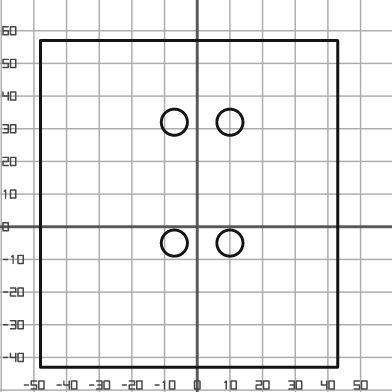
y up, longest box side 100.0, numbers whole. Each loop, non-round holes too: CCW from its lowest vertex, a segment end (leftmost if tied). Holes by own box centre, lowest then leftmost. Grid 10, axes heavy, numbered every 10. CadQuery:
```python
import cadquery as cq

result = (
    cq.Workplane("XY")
    .moveTo(-48.0, -43.0)
    .lineTo(43.0, -43.0)
    .lineTo(43.0, 57.0)
    .lineTo(-48.0, 57.0)
    .close()
    .moveTo(-7.0, -5.0)
    .circle(4.0)
    .moveTo(10.0, -5.0)
    .circle(4.0)
    .moveTo(-7.0, 32.0)
    .circle(4.0)
    .moveTo(10.0, 32.0)
    .circle(4.0)
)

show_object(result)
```